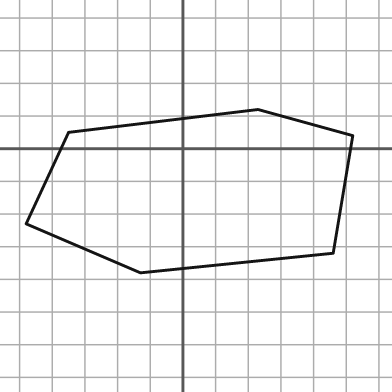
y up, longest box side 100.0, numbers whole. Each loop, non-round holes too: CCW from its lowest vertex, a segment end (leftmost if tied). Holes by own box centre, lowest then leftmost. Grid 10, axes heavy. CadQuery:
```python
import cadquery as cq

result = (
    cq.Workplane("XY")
    .moveTo(-13.0, -38.0)
    .lineTo(46.0, -32.0)
    .lineTo(52.0, 4.0)
    .lineTo(23.0, 12.0)
    .lineTo(-35.0, 5.0)
    .lineTo(-48.0, -23.0)
    .close()
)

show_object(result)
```